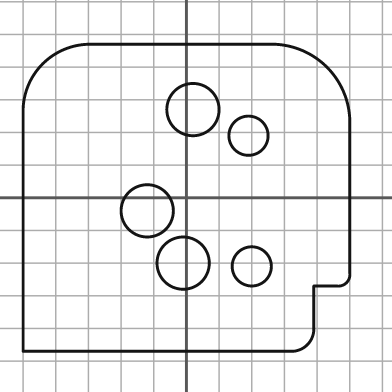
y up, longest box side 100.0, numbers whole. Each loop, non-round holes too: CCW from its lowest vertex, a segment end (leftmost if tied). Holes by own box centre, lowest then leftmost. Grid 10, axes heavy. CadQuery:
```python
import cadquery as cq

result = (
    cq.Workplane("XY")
    .moveTo(-50.0, -47.0)
    .lineTo(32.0, -47.0)
    .threePointArc((37.0, -45.0), (39.0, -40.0))
    .lineTo(39.0, -27.0)
    .lineTo(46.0, -27.0)
    .threePointArc((49.0, -26.0), (50.0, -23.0))
    .lineTo(50.0, 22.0)
    .threePointArc((43.0, 40.0), (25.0, 47.0))
    .lineTo(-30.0, 47.0)
    .threePointArc((-44.0, 41.0), (-50.0, 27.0))
    .close()
    .moveTo(20.0, -21.0)
    .circle(6.0)
    .moveTo(-1.0, -20.0)
    .circle(8.0)
    .moveTo(-12.0, -4.0)
    .circle(8.0)
    .moveTo(19.0, 19.0)
    .circle(6.0)
    .moveTo(2.0, 27.0)
    .circle(8.0)
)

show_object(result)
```